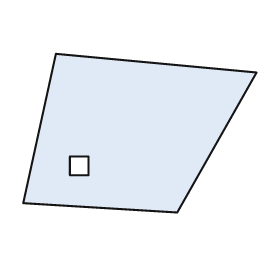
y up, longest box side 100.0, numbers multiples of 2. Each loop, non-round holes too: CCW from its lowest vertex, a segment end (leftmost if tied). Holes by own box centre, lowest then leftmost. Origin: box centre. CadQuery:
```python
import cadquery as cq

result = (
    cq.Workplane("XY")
    .moveTo(16.0, -34.0)
    .lineTo(50.0, 26.0)
    .lineTo(-36.0, 34.0)
    .lineTo(-50.0, -30.0)
    .close()
    .moveTo(-30.0, -18.0)
    .lineTo(-22.0, -18.0)
    .lineTo(-22.0, -10.0)
    .lineTo(-30.0, -10.0)
    .close()
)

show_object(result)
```